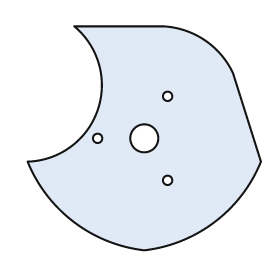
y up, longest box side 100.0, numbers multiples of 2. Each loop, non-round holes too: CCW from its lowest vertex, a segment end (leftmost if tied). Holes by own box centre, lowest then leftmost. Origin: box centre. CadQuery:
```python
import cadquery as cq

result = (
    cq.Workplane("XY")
    .moveTo(0.0, -48.0)
    .threePointArc((30.0, -36.0), (50.0, -10.0))
    .lineTo(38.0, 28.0)
    .threePointArc((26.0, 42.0), (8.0, 48.0))
    .lineTo(-30.0, 48.0)
    .threePointArc((-20.0, 12.0), (-50.0, -10.0))
    .threePointArc((-30.0, -36.0), (0.0, -48.0))
    .close()
    .moveTo(10.0, -18.0)
    .circle(2.0)
    .moveTo(-20.0, 0.0)
    .circle(2.0)
    .moveTo(0.0, 0.0)
    .circle(6.0)
    .moveTo(10.0, 18.0)
    .circle(2.0)
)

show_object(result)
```